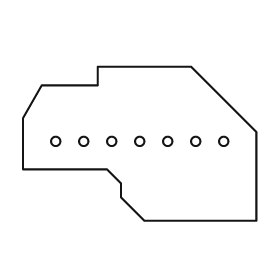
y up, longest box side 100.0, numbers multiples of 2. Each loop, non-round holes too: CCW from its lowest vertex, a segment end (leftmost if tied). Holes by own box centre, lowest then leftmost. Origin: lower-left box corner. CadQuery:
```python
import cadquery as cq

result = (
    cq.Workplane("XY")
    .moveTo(52.0, 0.0)
    .lineTo(100.0, 0.0)
    .lineTo(100.0, 38.0)
    .lineTo(72.0, 66.0)
    .lineTo(32.0, 66.0)
    .lineTo(32.0, 58.0)
    .lineTo(8.0, 58.0)
    .lineTo(0.0, 44.0)
    .lineTo(0.0, 22.0)
    .lineTo(36.0, 22.0)
    .lineTo(42.0, 16.0)
    .lineTo(42.0, 10.0)
    .close()
    .moveTo(14.0, 34.0)
    .circle(2.0)
    .moveTo(26.0, 34.0)
    .circle(2.0)
    .moveTo(38.0, 34.0)
    .circle(2.0)
    .moveTo(50.0, 34.0)
    .circle(2.0)
    .moveTo(62.0, 34.0)
    .circle(2.0)
    .moveTo(74.0, 34.0)
    .circle(2.0)
    .moveTo(86.0, 34.0)
    .circle(2.0)
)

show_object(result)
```